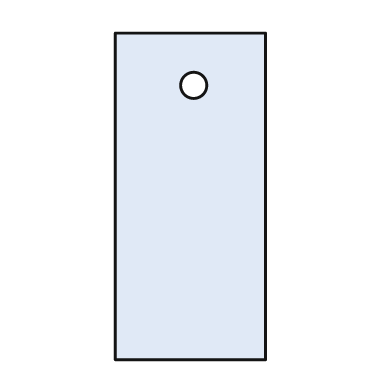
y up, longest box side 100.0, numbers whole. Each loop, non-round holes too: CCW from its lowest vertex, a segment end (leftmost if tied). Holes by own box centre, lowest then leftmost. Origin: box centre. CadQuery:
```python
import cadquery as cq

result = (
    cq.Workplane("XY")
    .moveTo(-23.0, -50.0)
    .lineTo(23.0, -50.0)
    .lineTo(23.0, 50.0)
    .lineTo(-23.0, 50.0)
    .close()
    .moveTo(1.0, 34.0)
    .circle(4.0)
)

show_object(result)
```